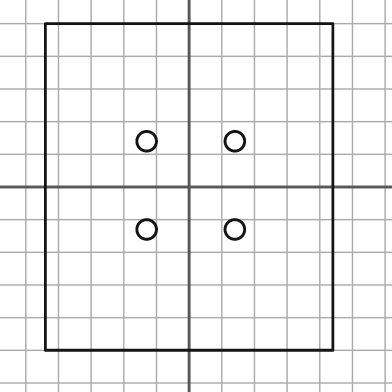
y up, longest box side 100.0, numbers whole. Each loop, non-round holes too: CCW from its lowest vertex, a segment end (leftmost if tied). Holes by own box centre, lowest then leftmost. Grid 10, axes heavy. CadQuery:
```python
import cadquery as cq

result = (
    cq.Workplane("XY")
    .moveTo(-44.0, -50.0)
    .lineTo(44.0, -50.0)
    .lineTo(44.0, 50.0)
    .lineTo(-44.0, 50.0)
    .close()
    .moveTo(-13.0, -13.0)
    .circle(3.0)
    .moveTo(14.0, -13.0)
    .circle(3.0)
    .moveTo(-13.0, 14.0)
    .circle(3.0)
    .moveTo(14.0, 14.0)
    .circle(3.0)
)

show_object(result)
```